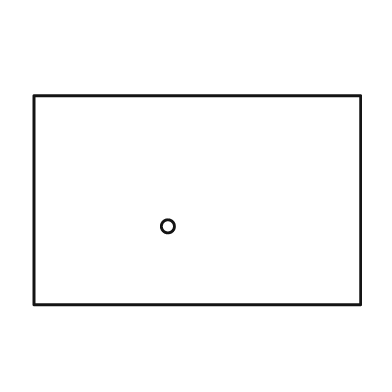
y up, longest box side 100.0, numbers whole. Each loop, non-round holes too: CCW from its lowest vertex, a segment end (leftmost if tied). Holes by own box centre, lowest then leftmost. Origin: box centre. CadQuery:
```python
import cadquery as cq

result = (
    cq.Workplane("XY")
    .moveTo(-50.0, -32.0)
    .lineTo(50.0, -32.0)
    .lineTo(50.0, 32.0)
    .lineTo(-50.0, 32.0)
    .close()
    .moveTo(-9.0, -8.0)
    .circle(2.0)
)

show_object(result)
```